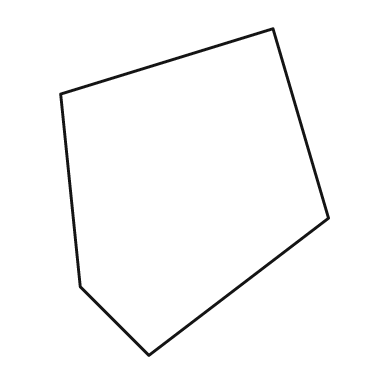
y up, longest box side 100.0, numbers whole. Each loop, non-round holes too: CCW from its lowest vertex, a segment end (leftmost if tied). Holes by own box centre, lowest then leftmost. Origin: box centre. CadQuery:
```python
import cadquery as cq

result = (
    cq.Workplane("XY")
    .moveTo(-14.0, -50.0)
    .lineTo(41.0, -8.0)
    .lineTo(24.0, 50.0)
    .lineTo(-41.0, 30.0)
    .lineTo(-35.0, -29.0)
    .close()
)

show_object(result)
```